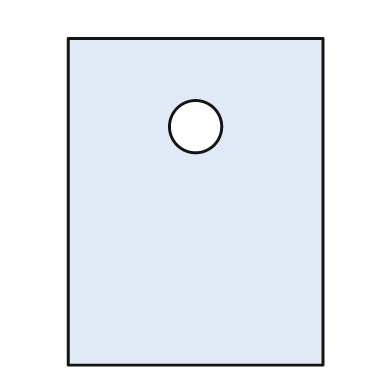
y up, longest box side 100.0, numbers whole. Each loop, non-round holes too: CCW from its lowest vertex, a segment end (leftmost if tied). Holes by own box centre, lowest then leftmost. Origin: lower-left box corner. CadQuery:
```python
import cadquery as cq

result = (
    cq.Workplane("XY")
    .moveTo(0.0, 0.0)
    .lineTo(78.0, 0.0)
    .lineTo(78.0, 100.0)
    .lineTo(0.0, 100.0)
    .close()
    .moveTo(39.0, 73.0)
    .circle(8.0)
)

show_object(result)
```